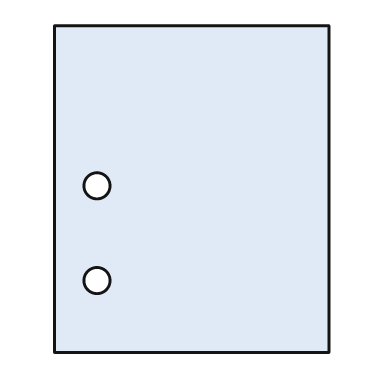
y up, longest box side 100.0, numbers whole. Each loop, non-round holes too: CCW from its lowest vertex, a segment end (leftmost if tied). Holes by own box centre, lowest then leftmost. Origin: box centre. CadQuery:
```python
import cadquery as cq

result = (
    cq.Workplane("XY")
    .moveTo(-42.0, -50.0)
    .lineTo(42.0, -50.0)
    .lineTo(42.0, 50.0)
    .lineTo(-42.0, 50.0)
    .close()
    .moveTo(-29.0, -28.0)
    .circle(4.0)
    .moveTo(-29.0, 1.0)
    .circle(4.0)
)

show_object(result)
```